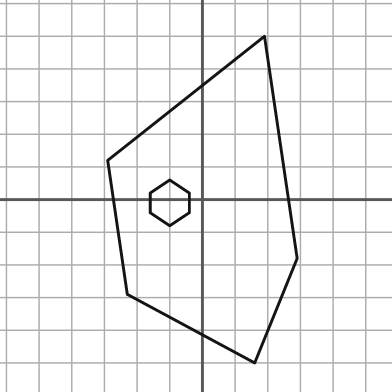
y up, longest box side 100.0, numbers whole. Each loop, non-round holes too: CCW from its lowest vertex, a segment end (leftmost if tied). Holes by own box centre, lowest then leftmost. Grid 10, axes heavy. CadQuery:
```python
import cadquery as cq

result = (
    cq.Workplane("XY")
    .moveTo(16.0, -50.0)
    .lineTo(29.0, -18.0)
    .lineTo(19.0, 50.0)
    .lineTo(-29.0, 12.0)
    .lineTo(-23.0, -29.0)
    .close()
    .moveTo(-10.0, -8.0)
    .lineTo(-4.0, -4.0)
    .lineTo(-4.0, 2.0)
    .lineTo(-10.0, 6.0)
    .lineTo(-16.0, 2.0)
    .lineTo(-16.0, -4.0)
    .close()
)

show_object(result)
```